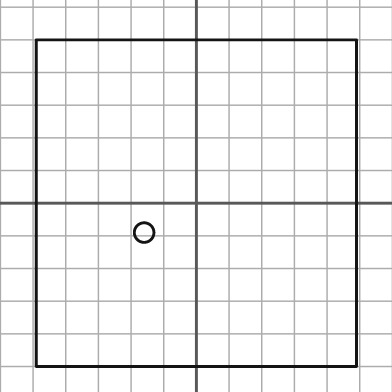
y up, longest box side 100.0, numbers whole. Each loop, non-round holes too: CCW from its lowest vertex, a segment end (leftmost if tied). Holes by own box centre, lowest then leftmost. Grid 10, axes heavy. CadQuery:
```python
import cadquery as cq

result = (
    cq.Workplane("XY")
    .moveTo(-49.0, -50.0)
    .lineTo(49.0, -50.0)
    .lineTo(49.0, 50.0)
    .lineTo(-49.0, 50.0)
    .close()
    .moveTo(-16.0, -9.0)
    .circle(3.0)
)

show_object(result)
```